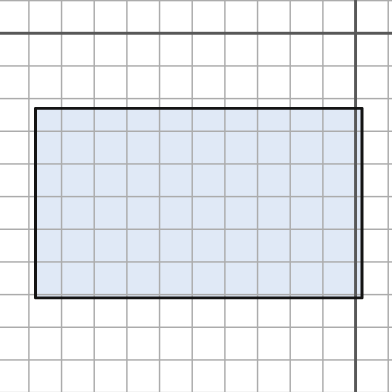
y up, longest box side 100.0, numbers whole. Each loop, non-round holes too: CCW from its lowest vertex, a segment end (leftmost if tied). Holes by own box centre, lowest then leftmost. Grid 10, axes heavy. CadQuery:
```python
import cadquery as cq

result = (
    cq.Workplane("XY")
    .moveTo(-98.0, -81.0)
    .lineTo(2.0, -81.0)
    .lineTo(2.0, -23.0)
    .lineTo(-98.0, -23.0)
    .close()
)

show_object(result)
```